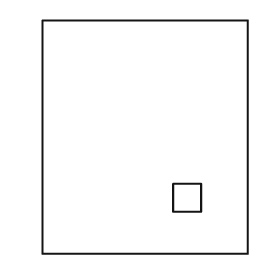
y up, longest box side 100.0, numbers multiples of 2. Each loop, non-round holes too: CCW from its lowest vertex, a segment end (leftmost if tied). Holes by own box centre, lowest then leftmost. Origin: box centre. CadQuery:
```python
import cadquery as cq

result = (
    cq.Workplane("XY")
    .moveTo(-44.0, -50.0)
    .lineTo(44.0, -50.0)
    .lineTo(44.0, 50.0)
    .lineTo(-44.0, 50.0)
    .close()
    .moveTo(12.0, -32.0)
    .lineTo(24.0, -32.0)
    .lineTo(24.0, -20.0)
    .lineTo(12.0, -20.0)
    .close()
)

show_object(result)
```